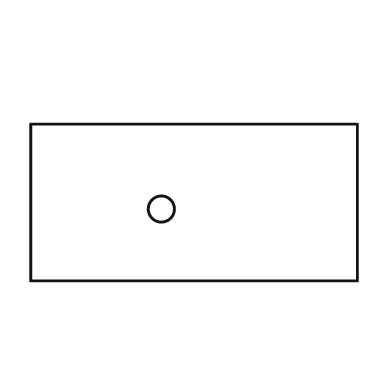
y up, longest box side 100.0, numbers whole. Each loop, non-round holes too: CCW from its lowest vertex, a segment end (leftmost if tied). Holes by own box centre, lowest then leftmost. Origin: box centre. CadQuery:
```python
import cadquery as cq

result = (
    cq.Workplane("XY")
    .moveTo(-50.0, -24.0)
    .lineTo(50.0, -24.0)
    .lineTo(50.0, 24.0)
    .lineTo(-50.0, 24.0)
    .close()
    .moveTo(-10.0, -2.0)
    .circle(4.0)
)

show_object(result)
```